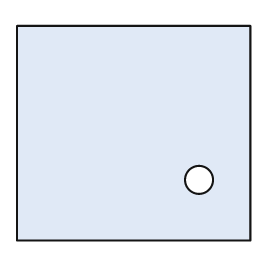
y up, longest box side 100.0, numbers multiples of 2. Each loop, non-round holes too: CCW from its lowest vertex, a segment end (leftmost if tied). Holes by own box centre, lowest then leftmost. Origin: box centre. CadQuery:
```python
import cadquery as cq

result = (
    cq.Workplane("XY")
    .moveTo(-50.0, -46.0)
    .lineTo(50.0, -46.0)
    .lineTo(50.0, 46.0)
    .lineTo(-50.0, 46.0)
    .close()
    .moveTo(28.0, -20.0)
    .circle(6.0)
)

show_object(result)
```